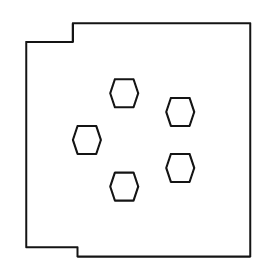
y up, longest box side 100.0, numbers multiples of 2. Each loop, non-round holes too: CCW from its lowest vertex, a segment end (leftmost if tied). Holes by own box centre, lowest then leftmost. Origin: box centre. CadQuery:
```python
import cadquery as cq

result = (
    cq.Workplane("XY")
    .moveTo(-26.0, -50.0)
    .lineTo(48.0, -50.0)
    .lineTo(48.0, 50.0)
    .lineTo(-28.0, 50.0)
    .lineTo(-28.0, 42.0)
    .lineTo(-48.0, 42.0)
    .lineTo(-48.0, -46.0)
    .lineTo(-26.0, -46.0)
    .close()
    .moveTo(-10.0, -26.0)
    .lineTo(-2.0, -26.0)
    .lineTo(0.0, -20.0)
    .lineTo(-2.0, -14.0)
    .lineTo(-10.0, -14.0)
    .lineTo(-12.0, -20.0)
    .close()
    .moveTo(14.0, -18.0)
    .lineTo(22.0, -18.0)
    .lineTo(24.0, -12.0)
    .lineTo(22.0, -6.0)
    .lineTo(14.0, -6.0)
    .lineTo(12.0, -12.0)
    .close()
    .moveTo(-26.0, -6.0)
    .lineTo(-18.0, -6.0)
    .lineTo(-16.0, 0.0)
    .lineTo(-18.0, 6.0)
    .lineTo(-26.0, 6.0)
    .lineTo(-28.0, 0.0)
    .close()
    .moveTo(14.0, 6.0)
    .lineTo(22.0, 6.0)
    .lineTo(24.0, 12.0)
    .lineTo(22.0, 18.0)
    .lineTo(14.0, 18.0)
    .lineTo(12.0, 12.0)
    .close()
    .moveTo(-10.0, 14.0)
    .lineTo(-2.0, 14.0)
    .lineTo(0.0, 20.0)
    .lineTo(-2.0, 26.0)
    .lineTo(-10.0, 26.0)
    .lineTo(-12.0, 20.0)
    .close()
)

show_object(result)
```